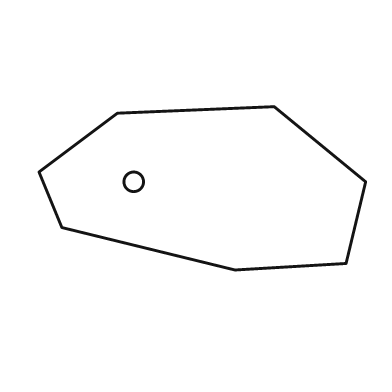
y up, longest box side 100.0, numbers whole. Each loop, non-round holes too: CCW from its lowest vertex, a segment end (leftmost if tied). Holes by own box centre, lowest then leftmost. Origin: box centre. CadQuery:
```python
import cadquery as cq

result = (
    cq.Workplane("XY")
    .moveTo(10.0, -25.0)
    .lineTo(44.0, -23.0)
    .lineTo(50.0, 2.0)
    .lineTo(22.0, 25.0)
    .lineTo(-26.0, 23.0)
    .lineTo(-50.0, 5.0)
    .lineTo(-43.0, -12.0)
    .close()
    .moveTo(-21.0, 2.0)
    .circle(3.0)
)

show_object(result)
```